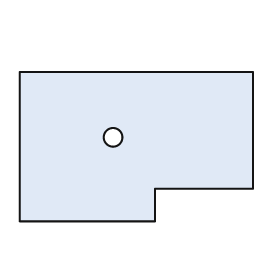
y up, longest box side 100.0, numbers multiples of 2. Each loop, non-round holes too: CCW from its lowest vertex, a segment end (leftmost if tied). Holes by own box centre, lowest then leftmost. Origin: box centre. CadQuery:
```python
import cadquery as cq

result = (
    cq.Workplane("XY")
    .moveTo(-50.0, -32.0)
    .lineTo(8.0, -32.0)
    .lineTo(8.0, -18.0)
    .lineTo(50.0, -18.0)
    .lineTo(50.0, 32.0)
    .lineTo(-50.0, 32.0)
    .close()
    .moveTo(-10.0, 4.0)
    .circle(4.0)
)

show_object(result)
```